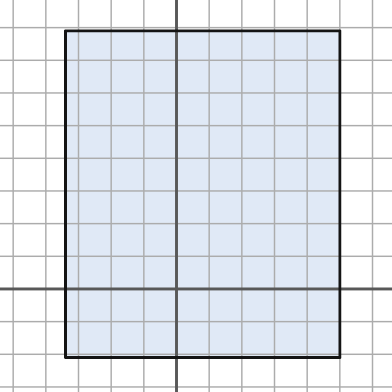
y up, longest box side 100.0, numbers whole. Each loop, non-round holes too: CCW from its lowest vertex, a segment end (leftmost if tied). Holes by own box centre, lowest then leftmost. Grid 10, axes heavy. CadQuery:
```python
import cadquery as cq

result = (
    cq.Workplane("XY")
    .moveTo(-34.0, -21.0)
    .lineTo(50.0, -21.0)
    .lineTo(50.0, 79.0)
    .lineTo(-34.0, 79.0)
    .close()
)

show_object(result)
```